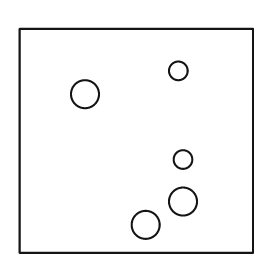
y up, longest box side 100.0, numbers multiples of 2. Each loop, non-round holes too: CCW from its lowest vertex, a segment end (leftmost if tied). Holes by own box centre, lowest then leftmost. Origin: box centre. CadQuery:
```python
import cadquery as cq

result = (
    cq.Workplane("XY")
    .moveTo(-50.0, -48.0)
    .lineTo(50.0, -48.0)
    .lineTo(50.0, 48.0)
    .lineTo(-50.0, 48.0)
    .close()
    .moveTo(4.0, -36.0)
    .circle(6.0)
    .moveTo(20.0, -26.0)
    .circle(6.0)
    .moveTo(20.0, -8.0)
    .circle(4.0)
    .moveTo(-22.0, 20.0)
    .circle(6.0)
    .moveTo(18.0, 30.0)
    .circle(4.0)
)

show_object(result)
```